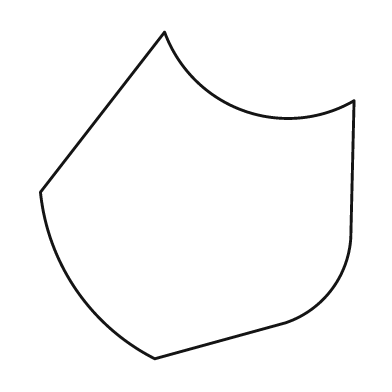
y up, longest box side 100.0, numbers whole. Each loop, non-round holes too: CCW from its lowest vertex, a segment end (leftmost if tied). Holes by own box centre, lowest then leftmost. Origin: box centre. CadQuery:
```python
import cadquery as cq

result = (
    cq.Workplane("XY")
    .moveTo(-13.0, -50.0)
    .lineTo(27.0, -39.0)
    .threePointArc((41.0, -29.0), (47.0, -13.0))
    .lineTo(48.0, 29.0)
    .threePointArc((14.0, 26.0), (-10.0, 50.0))
    .lineTo(-48.0, 1.0)
    .threePointArc((-37.0, -29.0), (-13.0, -50.0))
    .close()
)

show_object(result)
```